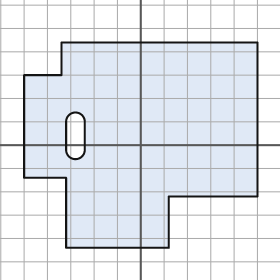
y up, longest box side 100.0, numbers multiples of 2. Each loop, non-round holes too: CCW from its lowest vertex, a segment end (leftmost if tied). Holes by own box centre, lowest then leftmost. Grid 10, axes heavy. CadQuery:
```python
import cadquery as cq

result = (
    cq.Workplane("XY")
    .moveTo(-32.0, -44.0)
    .lineTo(12.0, -44.0)
    .lineTo(12.0, -22.0)
    .lineTo(50.0, -22.0)
    .lineTo(50.0, 44.0)
    .lineTo(-34.0, 44.0)
    .lineTo(-34.0, 30.0)
    .lineTo(-50.0, 30.0)
    .lineTo(-50.0, -14.0)
    .lineTo(-32.0, -14.0)
    .close()
    .moveTo(-32.0, -2.0)
    .threePointArc((-28.0, -6.0), (-24.0, -2.0))
    .lineTo(-24.0, 10.0)
    .threePointArc((-28.0, 14.0), (-32.0, 10.0))
    .close()
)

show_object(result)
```